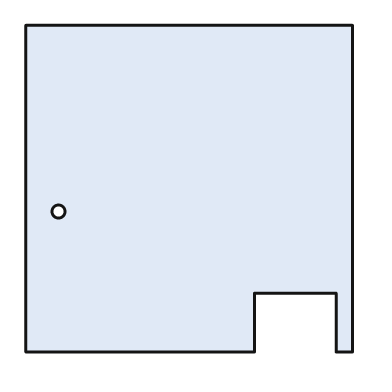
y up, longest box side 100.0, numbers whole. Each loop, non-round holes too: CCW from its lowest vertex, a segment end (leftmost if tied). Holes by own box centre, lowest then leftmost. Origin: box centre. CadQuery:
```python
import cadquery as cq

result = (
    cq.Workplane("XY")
    .moveTo(-50.0, -50.0)
    .lineTo(20.0, -50.0)
    .lineTo(20.0, -32.0)
    .lineTo(45.0, -32.0)
    .lineTo(45.0, -50.0)
    .lineTo(50.0, -50.0)
    .lineTo(50.0, 50.0)
    .lineTo(-50.0, 50.0)
    .close()
    .moveTo(-40.0, -7.0)
    .circle(2.0)
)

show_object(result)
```